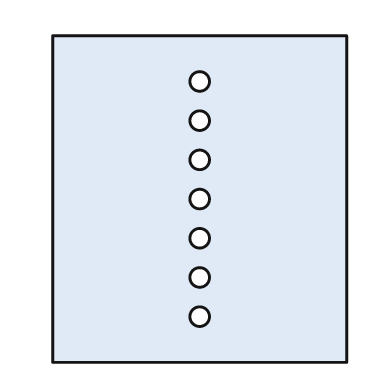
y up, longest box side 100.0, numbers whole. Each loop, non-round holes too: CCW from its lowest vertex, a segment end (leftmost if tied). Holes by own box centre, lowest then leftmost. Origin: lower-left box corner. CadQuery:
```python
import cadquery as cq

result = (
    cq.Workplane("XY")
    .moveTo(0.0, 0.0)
    .lineTo(90.0, 0.0)
    .lineTo(90.0, 100.0)
    .lineTo(0.0, 100.0)
    .close()
    .moveTo(45.0, 14.0)
    .circle(3.0)
    .moveTo(45.0, 26.0)
    .circle(3.0)
    .moveTo(45.0, 38.0)
    .circle(3.0)
    .moveTo(45.0, 50.0)
    .circle(3.0)
    .moveTo(45.0, 62.0)
    .circle(3.0)
    .moveTo(45.0, 74.0)
    .circle(3.0)
    .moveTo(45.0, 86.0)
    .circle(3.0)
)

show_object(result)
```